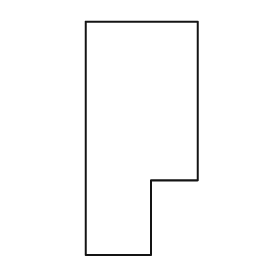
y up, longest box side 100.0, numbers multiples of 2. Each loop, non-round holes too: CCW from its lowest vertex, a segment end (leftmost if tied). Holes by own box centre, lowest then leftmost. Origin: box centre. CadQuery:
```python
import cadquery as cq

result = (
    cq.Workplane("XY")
    .moveTo(-24.0, -50.0)
    .lineTo(4.0, -50.0)
    .lineTo(4.0, -18.0)
    .lineTo(24.0, -18.0)
    .lineTo(24.0, 50.0)
    .lineTo(-24.0, 50.0)
    .close()
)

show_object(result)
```